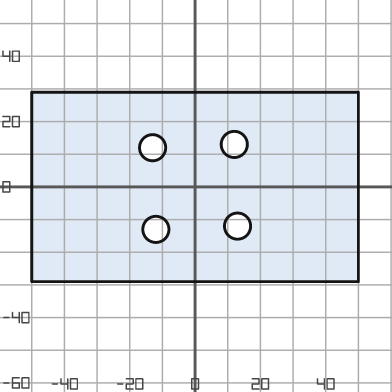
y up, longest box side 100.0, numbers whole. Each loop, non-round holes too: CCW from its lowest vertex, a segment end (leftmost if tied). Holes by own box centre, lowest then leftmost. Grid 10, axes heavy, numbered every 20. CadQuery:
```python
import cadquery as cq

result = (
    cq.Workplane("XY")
    .moveTo(-50.0, -29.0)
    .lineTo(50.0, -29.0)
    .lineTo(50.0, 29.0)
    .lineTo(-50.0, 29.0)
    .close()
    .moveTo(-12.0, -13.0)
    .circle(4.0)
    .moveTo(13.0, -12.0)
    .circle(4.0)
    .moveTo(-13.0, 12.0)
    .circle(4.0)
    .moveTo(12.0, 13.0)
    .circle(4.0)
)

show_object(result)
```